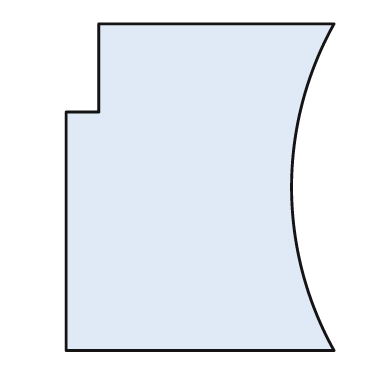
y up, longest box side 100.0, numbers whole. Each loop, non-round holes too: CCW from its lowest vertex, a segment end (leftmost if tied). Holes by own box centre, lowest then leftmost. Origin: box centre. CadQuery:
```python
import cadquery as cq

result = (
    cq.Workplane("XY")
    .moveTo(-41.0, -50.0)
    .lineTo(41.0, -50.0)
    .threePointArc((28.0, 0.0), (41.0, 50.0))
    .lineTo(-31.0, 50.0)
    .lineTo(-31.0, 23.0)
    .lineTo(-41.0, 23.0)
    .close()
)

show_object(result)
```